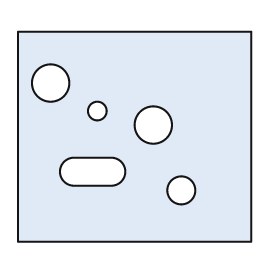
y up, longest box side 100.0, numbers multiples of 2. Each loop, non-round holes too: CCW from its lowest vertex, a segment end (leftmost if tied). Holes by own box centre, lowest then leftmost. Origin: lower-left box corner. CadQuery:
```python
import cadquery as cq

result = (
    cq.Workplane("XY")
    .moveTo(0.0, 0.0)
    .lineTo(100.0, 0.0)
    .lineTo(100.0, 90.0)
    .lineTo(0.0, 90.0)
    .close()
    .moveTo(70.0, 22.0)
    .circle(6.0)
    .moveTo(24.0, 24.0)
    .lineTo(40.0, 24.0)
    .threePointArc((46.0, 30.0), (40.0, 36.0))
    .lineTo(24.0, 36.0)
    .threePointArc((18.0, 30.0), (24.0, 24.0))
    .close()
    .moveTo(58.0, 50.0)
    .circle(8.0)
    .moveTo(34.0, 56.0)
    .circle(4.0)
    .moveTo(14.0, 68.0)
    .circle(8.0)
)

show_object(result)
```